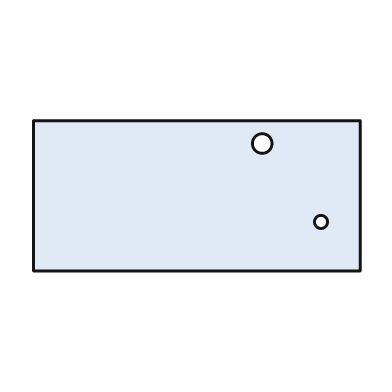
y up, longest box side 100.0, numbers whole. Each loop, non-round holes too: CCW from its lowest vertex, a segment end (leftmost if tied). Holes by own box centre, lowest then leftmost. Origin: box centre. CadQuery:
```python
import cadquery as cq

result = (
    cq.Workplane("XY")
    .moveTo(-50.0, -23.0)
    .lineTo(50.0, -23.0)
    .lineTo(50.0, 23.0)
    .lineTo(-50.0, 23.0)
    .close()
    .moveTo(38.0, -8.0)
    .circle(2.0)
    .moveTo(20.0, 16.0)
    .circle(3.0)
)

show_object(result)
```